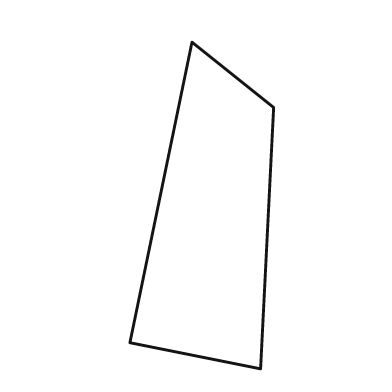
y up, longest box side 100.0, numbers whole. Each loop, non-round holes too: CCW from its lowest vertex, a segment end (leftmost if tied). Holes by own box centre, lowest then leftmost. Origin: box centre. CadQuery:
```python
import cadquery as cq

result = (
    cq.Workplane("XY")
    .moveTo(18.0, -50.0)
    .lineTo(22.0, 30.0)
    .lineTo(-3.0, 50.0)
    .lineTo(-22.0, -42.0)
    .close()
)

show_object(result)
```